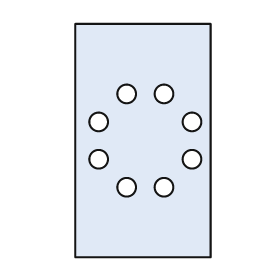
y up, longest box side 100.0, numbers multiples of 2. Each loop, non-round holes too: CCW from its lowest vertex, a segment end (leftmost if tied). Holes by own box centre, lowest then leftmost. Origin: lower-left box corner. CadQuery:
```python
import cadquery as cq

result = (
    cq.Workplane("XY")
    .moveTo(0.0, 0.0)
    .lineTo(58.0, 0.0)
    .lineTo(58.0, 100.0)
    .lineTo(0.0, 100.0)
    .close()
    .moveTo(22.0, 30.0)
    .circle(4.0)
    .moveTo(38.0, 30.0)
    .circle(4.0)
    .moveTo(10.0, 42.0)
    .circle(4.0)
    .moveTo(50.0, 42.0)
    .circle(4.0)
    .moveTo(10.0, 58.0)
    .circle(4.0)
    .moveTo(50.0, 58.0)
    .circle(4.0)
    .moveTo(22.0, 70.0)
    .circle(4.0)
    .moveTo(38.0, 70.0)
    .circle(4.0)
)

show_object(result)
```